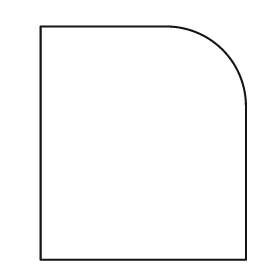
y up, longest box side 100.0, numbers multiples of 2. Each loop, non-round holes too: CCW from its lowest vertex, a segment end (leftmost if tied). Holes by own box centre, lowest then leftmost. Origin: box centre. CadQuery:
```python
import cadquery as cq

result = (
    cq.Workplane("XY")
    .moveTo(-44.0, -50.0)
    .lineTo(44.0, -50.0)
    .lineTo(44.0, 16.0)
    .threePointArc((34.0, 40.0), (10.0, 50.0))
    .lineTo(-44.0, 50.0)
    .close()
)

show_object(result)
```